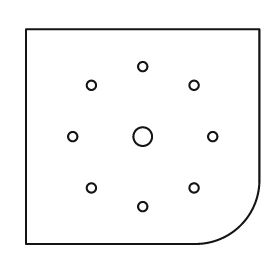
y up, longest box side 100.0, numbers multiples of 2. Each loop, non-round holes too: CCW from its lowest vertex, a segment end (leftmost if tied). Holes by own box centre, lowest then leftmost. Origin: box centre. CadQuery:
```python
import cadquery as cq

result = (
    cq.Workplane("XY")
    .moveTo(-50.0, -46.0)
    .lineTo(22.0, -46.0)
    .threePointArc((42.0, -38.0), (50.0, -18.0))
    .lineTo(50.0, 46.0)
    .lineTo(-50.0, 46.0)
    .close()
    .moveTo(0.0, -30.0)
    .circle(2.0)
    .moveTo(-22.0, -22.0)
    .circle(2.0)
    .moveTo(22.0, -22.0)
    .circle(2.0)
    .moveTo(-30.0, 0.0)
    .circle(2.0)
    .moveTo(0.0, 0.0)
    .circle(4.0)
    .moveTo(30.0, 0.0)
    .circle(2.0)
    .moveTo(-22.0, 22.0)
    .circle(2.0)
    .moveTo(22.0, 22.0)
    .circle(2.0)
    .moveTo(0.0, 30.0)
    .circle(2.0)
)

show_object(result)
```